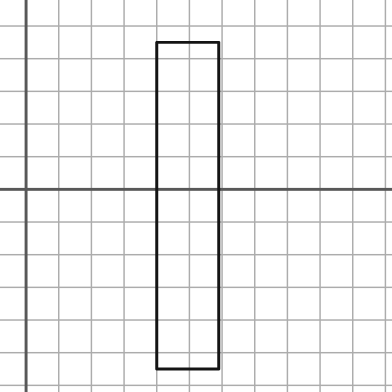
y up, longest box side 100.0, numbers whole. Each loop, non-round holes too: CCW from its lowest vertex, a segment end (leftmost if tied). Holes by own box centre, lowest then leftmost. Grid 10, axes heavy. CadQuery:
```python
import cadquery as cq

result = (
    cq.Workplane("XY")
    .moveTo(40.0, -55.0)
    .lineTo(59.0, -55.0)
    .lineTo(59.0, 45.0)
    .lineTo(40.0, 45.0)
    .close()
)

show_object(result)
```